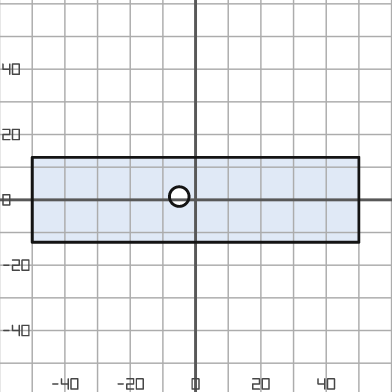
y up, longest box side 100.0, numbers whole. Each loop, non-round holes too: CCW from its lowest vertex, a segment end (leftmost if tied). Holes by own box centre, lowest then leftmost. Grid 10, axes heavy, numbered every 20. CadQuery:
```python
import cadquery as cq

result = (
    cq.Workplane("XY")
    .moveTo(-50.0, -13.0)
    .lineTo(50.0, -13.0)
    .lineTo(50.0, 13.0)
    .lineTo(-50.0, 13.0)
    .close()
    .moveTo(-5.0, 1.0)
    .circle(3.0)
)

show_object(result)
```